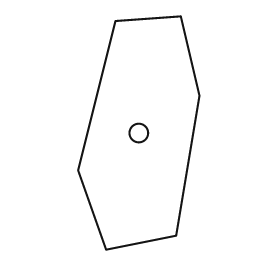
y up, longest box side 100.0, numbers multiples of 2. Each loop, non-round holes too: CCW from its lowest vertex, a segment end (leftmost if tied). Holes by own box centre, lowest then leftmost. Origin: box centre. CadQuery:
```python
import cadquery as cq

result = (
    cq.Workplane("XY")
    .moveTo(-14.0, -50.0)
    .lineTo(16.0, -44.0)
    .lineTo(26.0, 16.0)
    .lineTo(18.0, 50.0)
    .lineTo(-10.0, 48.0)
    .lineTo(-26.0, -16.0)
    .close()
    .moveTo(0.0, 0.0)
    .circle(4.0)
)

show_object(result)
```